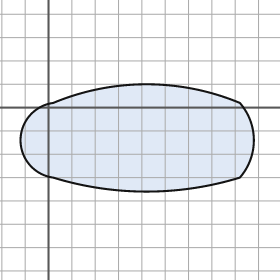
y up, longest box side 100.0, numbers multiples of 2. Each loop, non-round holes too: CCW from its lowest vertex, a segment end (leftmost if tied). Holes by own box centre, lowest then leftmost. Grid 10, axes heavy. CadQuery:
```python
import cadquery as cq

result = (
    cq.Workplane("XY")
    .moveTo(2.0, -30.0)
    .threePointArc((42.0, -36.0), (82.0, -30.0))
    .threePointArc((88.0, -14.0), (82.0, 2.0))
    .threePointArc((42.0, 10.0), (2.0, 2.0))
    .threePointArc((-12.0, -14.0), (2.0, -30.0))
    .close()
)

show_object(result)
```